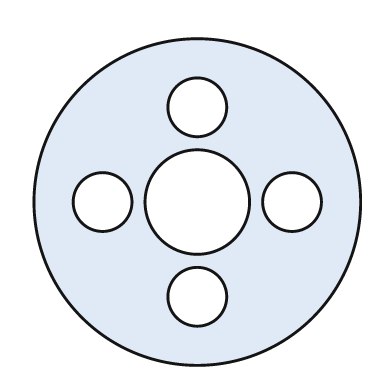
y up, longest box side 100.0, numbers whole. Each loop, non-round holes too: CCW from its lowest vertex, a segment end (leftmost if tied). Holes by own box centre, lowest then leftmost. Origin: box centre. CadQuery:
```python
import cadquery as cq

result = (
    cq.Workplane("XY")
    .moveTo(0.0, 0.0)
    .circle(50.0)
    .moveTo(0.0, -29.0)
    .circle(9.0)
    .moveTo(-29.0, 0.0)
    .circle(9.0)
    .moveTo(0.0, 0.0)
    .circle(16.0)
    .moveTo(29.0, 0.0)
    .circle(9.0)
    .moveTo(0.0, 29.0)
    .circle(9.0)
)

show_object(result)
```